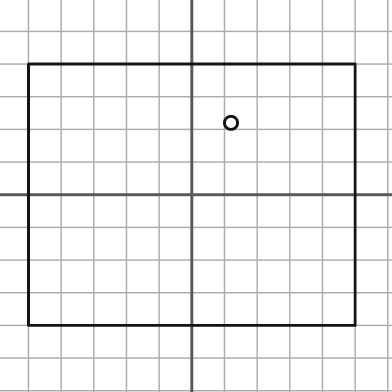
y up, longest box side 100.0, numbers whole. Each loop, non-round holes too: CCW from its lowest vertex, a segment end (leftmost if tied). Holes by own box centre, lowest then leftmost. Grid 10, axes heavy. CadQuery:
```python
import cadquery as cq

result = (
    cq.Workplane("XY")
    .moveTo(-50.0, -40.0)
    .lineTo(50.0, -40.0)
    .lineTo(50.0, 40.0)
    .lineTo(-50.0, 40.0)
    .close()
    .moveTo(12.0, 22.0)
    .circle(2.0)
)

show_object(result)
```